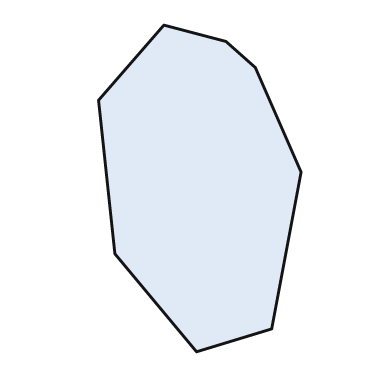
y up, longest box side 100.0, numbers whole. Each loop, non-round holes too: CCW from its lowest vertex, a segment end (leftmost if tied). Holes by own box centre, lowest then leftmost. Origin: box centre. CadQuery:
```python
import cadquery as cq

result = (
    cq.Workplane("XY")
    .moveTo(-1.0, -50.0)
    .lineTo(22.0, -43.0)
    .lineTo(31.0, 5.0)
    .lineTo(17.0, 37.0)
    .lineTo(8.0, 45.0)
    .lineTo(-11.0, 50.0)
    .lineTo(-31.0, 27.0)
    .lineTo(-26.0, -20.0)
    .close()
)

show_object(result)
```